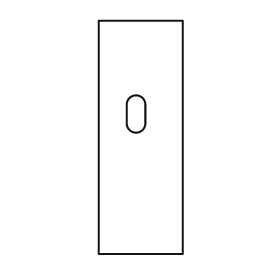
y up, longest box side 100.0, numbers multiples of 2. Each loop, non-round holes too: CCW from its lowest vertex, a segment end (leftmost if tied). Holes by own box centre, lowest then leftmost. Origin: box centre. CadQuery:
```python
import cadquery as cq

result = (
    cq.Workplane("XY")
    .moveTo(-18.0, -50.0)
    .lineTo(18.0, -50.0)
    .lineTo(18.0, 50.0)
    .lineTo(-18.0, 50.0)
    .close()
    .moveTo(-6.0, 6.0)
    .threePointArc((-2.0, 2.0), (2.0, 6.0))
    .lineTo(2.0, 14.0)
    .threePointArc((-2.0, 18.0), (-6.0, 14.0))
    .close()
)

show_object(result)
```